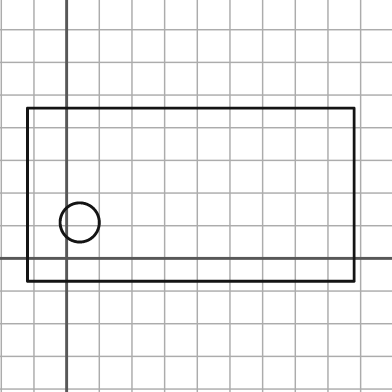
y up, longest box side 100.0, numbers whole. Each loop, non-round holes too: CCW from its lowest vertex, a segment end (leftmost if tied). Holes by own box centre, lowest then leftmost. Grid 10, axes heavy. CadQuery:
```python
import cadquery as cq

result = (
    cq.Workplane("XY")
    .moveTo(-12.0, -7.0)
    .lineTo(88.0, -7.0)
    .lineTo(88.0, 46.0)
    .lineTo(-12.0, 46.0)
    .close()
    .moveTo(4.0, 11.0)
    .circle(6.0)
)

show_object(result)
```